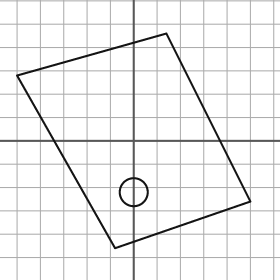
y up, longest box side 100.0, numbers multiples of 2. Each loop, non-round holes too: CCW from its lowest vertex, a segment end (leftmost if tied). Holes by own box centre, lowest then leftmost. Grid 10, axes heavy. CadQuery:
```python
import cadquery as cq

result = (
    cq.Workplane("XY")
    .moveTo(-8.0, -46.0)
    .lineTo(50.0, -26.0)
    .lineTo(14.0, 46.0)
    .lineTo(-50.0, 28.0)
    .close()
    .moveTo(0.0, -22.0)
    .circle(6.0)
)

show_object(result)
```